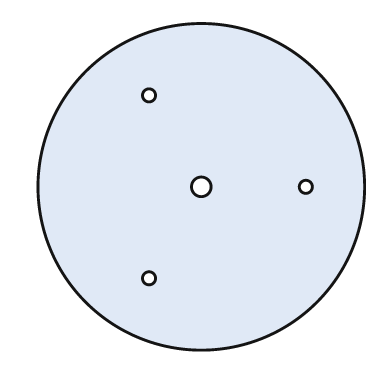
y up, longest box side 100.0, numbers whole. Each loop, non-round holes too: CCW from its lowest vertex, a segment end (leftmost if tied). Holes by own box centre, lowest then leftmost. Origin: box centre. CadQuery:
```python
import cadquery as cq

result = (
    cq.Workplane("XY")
    .moveTo(0.0, 0.0)
    .circle(50.0)
    .moveTo(-16.0, -28.0)
    .circle(2.0)
    .moveTo(0.0, 0.0)
    .circle(3.0)
    .moveTo(32.0, 0.0)
    .circle(2.0)
    .moveTo(-16.0, 28.0)
    .circle(2.0)
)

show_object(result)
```